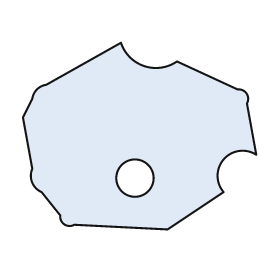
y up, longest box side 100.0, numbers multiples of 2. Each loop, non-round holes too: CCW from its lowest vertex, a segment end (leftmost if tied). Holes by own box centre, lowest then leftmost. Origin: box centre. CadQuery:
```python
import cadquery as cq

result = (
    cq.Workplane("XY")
    .moveTo(12.0, -40.0)
    .lineTo(36.0, -24.0)
    .threePointArc((36.0, -10.0), (50.0, -8.0))
    .lineTo(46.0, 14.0)
    .threePointArc((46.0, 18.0), (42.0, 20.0))
    .lineTo(16.0, 32.0)
    .threePointArc((2.0, 30.0), (-8.0, 40.0))
    .lineTo(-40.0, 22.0)
    .threePointArc((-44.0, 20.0), (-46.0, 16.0))
    .lineTo(-50.0, 8.0)
    .lineTo(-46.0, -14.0)
    .threePointArc((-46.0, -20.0), (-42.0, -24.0))
    .lineTo(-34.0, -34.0)
    .threePointArc((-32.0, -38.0), (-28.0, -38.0))
    .close()
    .moveTo(-2.0, -18.0)
    .circle(8.0)
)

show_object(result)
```